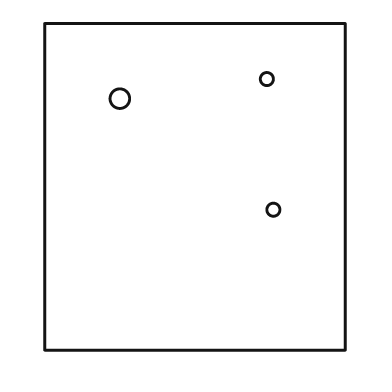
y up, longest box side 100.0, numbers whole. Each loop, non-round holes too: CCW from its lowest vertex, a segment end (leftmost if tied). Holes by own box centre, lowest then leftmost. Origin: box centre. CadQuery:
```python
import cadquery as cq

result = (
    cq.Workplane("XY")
    .moveTo(-46.0, -50.0)
    .lineTo(46.0, -50.0)
    .lineTo(46.0, 50.0)
    .lineTo(-46.0, 50.0)
    .close()
    .moveTo(24.0, -7.0)
    .circle(2.0)
    .moveTo(-23.0, 27.0)
    .circle(3.0)
    .moveTo(22.0, 33.0)
    .circle(2.0)
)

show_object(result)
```